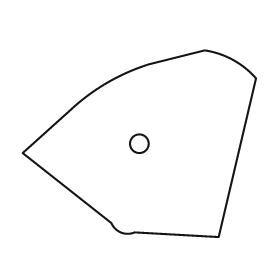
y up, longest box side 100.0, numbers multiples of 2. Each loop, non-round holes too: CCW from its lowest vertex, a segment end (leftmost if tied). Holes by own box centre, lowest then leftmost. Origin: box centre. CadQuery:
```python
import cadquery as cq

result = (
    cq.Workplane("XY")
    .moveTo(34.0, -40.0)
    .lineTo(50.0, 28.0)
    .threePointArc((40.0, 36.0), (28.0, 40.0))
    .lineTo(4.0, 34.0)
    .threePointArc((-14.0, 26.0), (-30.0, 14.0))
    .lineTo(-50.0, -4.0)
    .lineTo(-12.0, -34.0)
    .threePointArc((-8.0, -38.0), (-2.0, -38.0))
    .close()
    .moveTo(0.0, 0.0)
    .circle(4.0)
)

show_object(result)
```